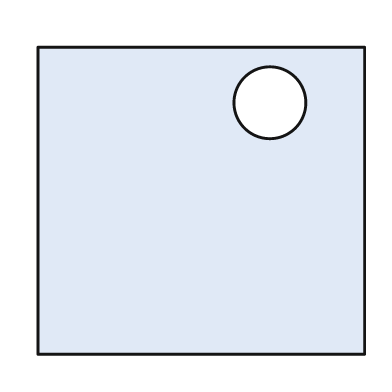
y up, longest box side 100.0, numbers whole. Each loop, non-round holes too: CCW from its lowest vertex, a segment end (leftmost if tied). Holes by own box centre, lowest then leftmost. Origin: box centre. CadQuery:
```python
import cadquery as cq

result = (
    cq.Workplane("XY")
    .moveTo(-50.0, -47.0)
    .lineTo(50.0, -47.0)
    .lineTo(50.0, 47.0)
    .lineTo(-50.0, 47.0)
    .close()
    .moveTo(21.0, 30.0)
    .circle(11.0)
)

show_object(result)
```